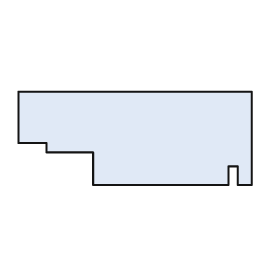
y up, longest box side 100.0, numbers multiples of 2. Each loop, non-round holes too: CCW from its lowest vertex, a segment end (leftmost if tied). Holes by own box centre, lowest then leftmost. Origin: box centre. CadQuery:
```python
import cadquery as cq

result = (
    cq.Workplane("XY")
    .moveTo(-18.0, -20.0)
    .lineTo(40.0, -20.0)
    .lineTo(40.0, -12.0)
    .lineTo(44.0, -12.0)
    .lineTo(44.0, -20.0)
    .lineTo(50.0, -20.0)
    .lineTo(50.0, 20.0)
    .lineTo(-50.0, 20.0)
    .lineTo(-50.0, -2.0)
    .lineTo(-38.0, -2.0)
    .lineTo(-38.0, -6.0)
    .lineTo(-18.0, -6.0)
    .close()
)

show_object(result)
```